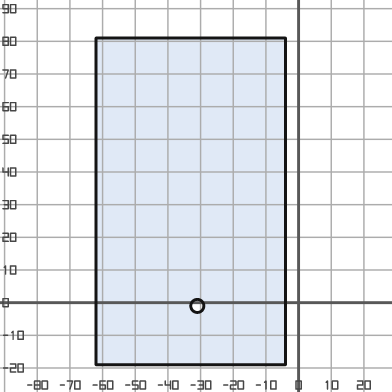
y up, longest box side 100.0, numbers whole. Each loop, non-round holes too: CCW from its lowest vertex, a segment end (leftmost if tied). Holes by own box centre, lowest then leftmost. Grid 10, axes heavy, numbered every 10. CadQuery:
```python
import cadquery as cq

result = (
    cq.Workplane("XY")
    .moveTo(-62.0, -19.0)
    .lineTo(-4.0, -19.0)
    .lineTo(-4.0, 81.0)
    .lineTo(-62.0, 81.0)
    .close()
    .moveTo(-31.0, -1.0)
    .circle(2.0)
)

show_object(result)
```